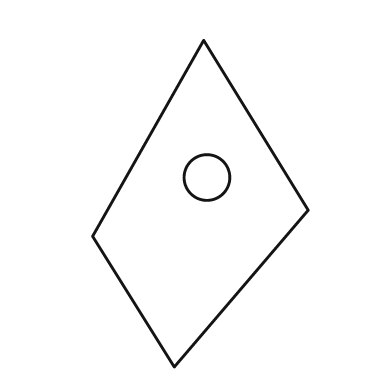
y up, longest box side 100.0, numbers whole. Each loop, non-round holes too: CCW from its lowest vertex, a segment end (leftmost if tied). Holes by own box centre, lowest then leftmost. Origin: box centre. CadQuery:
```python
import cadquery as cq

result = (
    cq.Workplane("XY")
    .moveTo(-8.0, -50.0)
    .lineTo(33.0, -2.0)
    .lineTo(1.0, 50.0)
    .lineTo(-33.0, -10.0)
    .close()
    .moveTo(2.0, 8.0)
    .circle(7.0)
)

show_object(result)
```